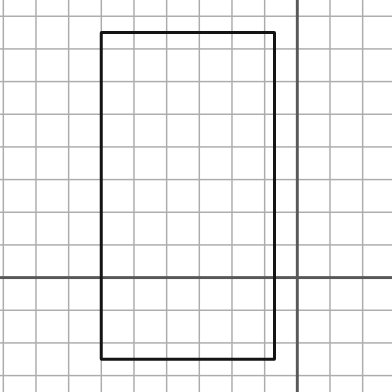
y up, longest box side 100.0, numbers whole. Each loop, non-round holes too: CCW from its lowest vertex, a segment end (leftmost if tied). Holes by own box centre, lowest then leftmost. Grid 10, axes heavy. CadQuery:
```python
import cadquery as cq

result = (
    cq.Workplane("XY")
    .moveTo(-60.0, -25.0)
    .lineTo(-7.0, -25.0)
    .lineTo(-7.0, 75.0)
    .lineTo(-60.0, 75.0)
    .close()
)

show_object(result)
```